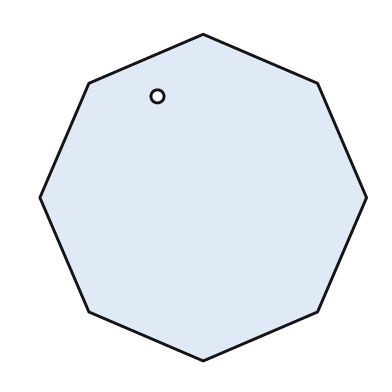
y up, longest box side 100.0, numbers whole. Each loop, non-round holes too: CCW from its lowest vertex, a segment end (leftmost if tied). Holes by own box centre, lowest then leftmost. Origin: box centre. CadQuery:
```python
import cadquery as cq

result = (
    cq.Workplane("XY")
    .moveTo(0.0, -50.0)
    .lineTo(35.0, -35.0)
    .lineTo(50.0, 0.0)
    .lineTo(35.0, 35.0)
    .lineTo(0.0, 50.0)
    .lineTo(-35.0, 35.0)
    .lineTo(-50.0, 0.0)
    .lineTo(-35.0, -35.0)
    .close()
    .moveTo(-14.0, 31.0)
    .circle(2.0)
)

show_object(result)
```